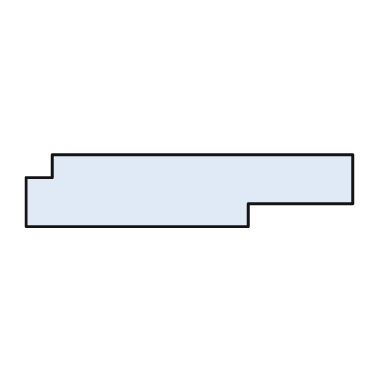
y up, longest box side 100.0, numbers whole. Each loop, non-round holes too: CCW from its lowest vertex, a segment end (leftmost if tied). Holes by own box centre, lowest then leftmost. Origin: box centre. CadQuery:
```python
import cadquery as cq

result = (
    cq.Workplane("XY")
    .moveTo(-50.0, -11.0)
    .lineTo(18.0, -11.0)
    .lineTo(18.0, -4.0)
    .lineTo(50.0, -4.0)
    .lineTo(50.0, 11.0)
    .lineTo(-42.0, 11.0)
    .lineTo(-42.0, 4.0)
    .lineTo(-50.0, 4.0)
    .close()
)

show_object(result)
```